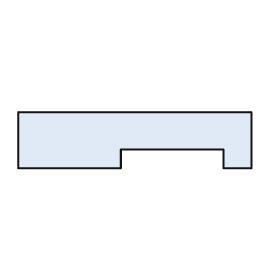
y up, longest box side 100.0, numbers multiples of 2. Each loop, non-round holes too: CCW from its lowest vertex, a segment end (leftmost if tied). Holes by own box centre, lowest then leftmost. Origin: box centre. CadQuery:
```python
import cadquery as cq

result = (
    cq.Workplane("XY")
    .moveTo(-50.0, -12.0)
    .lineTo(-6.0, -12.0)
    .lineTo(-6.0, -4.0)
    .lineTo(38.0, -4.0)
    .lineTo(38.0, -12.0)
    .lineTo(50.0, -12.0)
    .lineTo(50.0, 12.0)
    .lineTo(-50.0, 12.0)
    .close()
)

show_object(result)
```